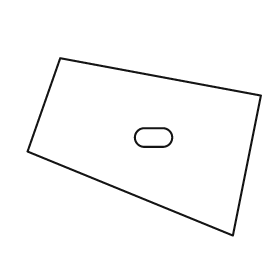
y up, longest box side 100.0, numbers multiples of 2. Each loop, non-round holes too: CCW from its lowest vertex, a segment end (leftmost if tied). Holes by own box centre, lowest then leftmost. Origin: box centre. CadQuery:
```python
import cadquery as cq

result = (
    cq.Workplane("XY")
    .moveTo(38.0, -38.0)
    .lineTo(50.0, 22.0)
    .lineTo(-36.0, 38.0)
    .lineTo(-50.0, -2.0)
    .close()
    .moveTo(0.0, 0.0)
    .lineTo(8.0, 0.0)
    .threePointArc((12.0, 4.0), (8.0, 8.0))
    .lineTo(0.0, 8.0)
    .threePointArc((-4.0, 4.0), (0.0, 0.0))
    .close()
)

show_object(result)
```